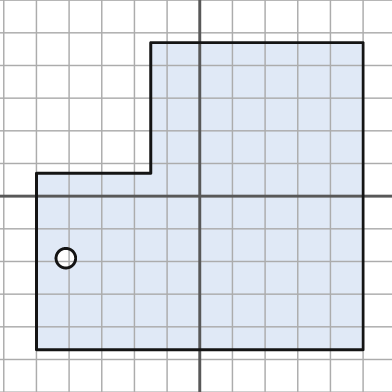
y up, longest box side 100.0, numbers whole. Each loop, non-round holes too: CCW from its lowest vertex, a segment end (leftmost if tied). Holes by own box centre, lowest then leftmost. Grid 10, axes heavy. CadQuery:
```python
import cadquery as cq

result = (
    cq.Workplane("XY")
    .moveTo(-50.0, -47.0)
    .lineTo(50.0, -47.0)
    .lineTo(50.0, 47.0)
    .lineTo(-15.0, 47.0)
    .lineTo(-15.0, 7.0)
    .lineTo(-50.0, 7.0)
    .close()
    .moveTo(-41.0, -19.0)
    .circle(3.0)
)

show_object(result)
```